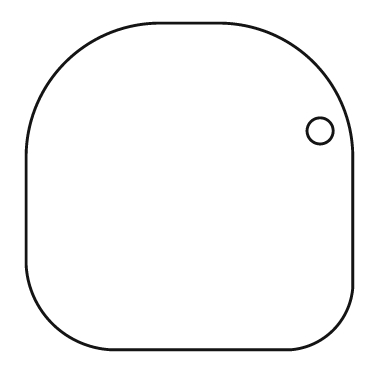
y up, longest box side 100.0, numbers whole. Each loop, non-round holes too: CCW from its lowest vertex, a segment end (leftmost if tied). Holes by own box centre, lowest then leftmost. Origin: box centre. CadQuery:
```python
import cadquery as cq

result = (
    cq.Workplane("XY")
    .moveTo(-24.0, -50.0)
    .lineTo(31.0, -50.0)
    .threePointArc((44.0, -44.0), (50.0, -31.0))
    .lineTo(50.0, 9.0)
    .threePointArc((38.0, 38.0), (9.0, 50.0))
    .lineTo(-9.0, 50.0)
    .threePointArc((-38.0, 38.0), (-50.0, 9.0))
    .lineTo(-50.0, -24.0)
    .threePointArc((-42.0, -42.0), (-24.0, -50.0))
    .close()
    .moveTo(40.0, 17.0)
    .circle(4.0)
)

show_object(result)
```